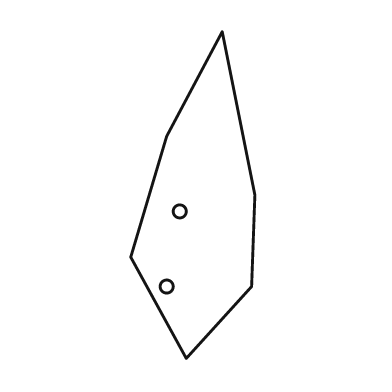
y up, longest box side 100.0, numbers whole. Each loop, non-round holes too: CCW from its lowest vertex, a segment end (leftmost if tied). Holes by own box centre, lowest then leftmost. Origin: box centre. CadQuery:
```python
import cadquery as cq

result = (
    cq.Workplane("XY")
    .moveTo(-2.0, -50.0)
    .lineTo(18.0, -28.0)
    .lineTo(19.0, 0.0)
    .lineTo(9.0, 50.0)
    .lineTo(-8.0, 18.0)
    .lineTo(-19.0, -19.0)
    .close()
    .moveTo(-8.0, -28.0)
    .circle(2.0)
    .moveTo(-4.0, -5.0)
    .circle(2.0)
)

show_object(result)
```